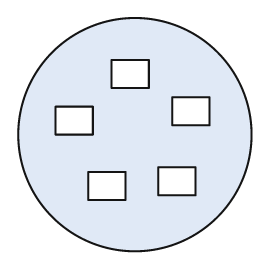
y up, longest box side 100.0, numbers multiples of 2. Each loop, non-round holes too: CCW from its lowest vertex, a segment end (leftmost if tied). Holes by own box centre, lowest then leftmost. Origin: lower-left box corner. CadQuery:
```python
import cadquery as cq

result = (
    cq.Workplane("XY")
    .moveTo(50.0, 50.0)
    .circle(50.0)
    .moveTo(30.0, 22.0)
    .lineTo(46.0, 22.0)
    .lineTo(46.0, 34.0)
    .lineTo(30.0, 34.0)
    .close()
    .moveTo(60.0, 24.0)
    .lineTo(76.0, 24.0)
    .lineTo(76.0, 36.0)
    .lineTo(60.0, 36.0)
    .close()
    .moveTo(16.0, 50.0)
    .lineTo(32.0, 50.0)
    .lineTo(32.0, 62.0)
    .lineTo(16.0, 62.0)
    .close()
    .moveTo(66.0, 54.0)
    .lineTo(82.0, 54.0)
    .lineTo(82.0, 66.0)
    .lineTo(66.0, 66.0)
    .close()
    .moveTo(40.0, 70.0)
    .lineTo(56.0, 70.0)
    .lineTo(56.0, 82.0)
    .lineTo(40.0, 82.0)
    .close()
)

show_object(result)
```